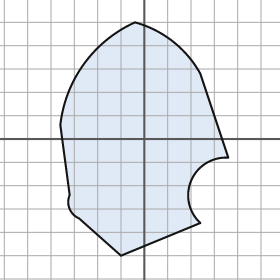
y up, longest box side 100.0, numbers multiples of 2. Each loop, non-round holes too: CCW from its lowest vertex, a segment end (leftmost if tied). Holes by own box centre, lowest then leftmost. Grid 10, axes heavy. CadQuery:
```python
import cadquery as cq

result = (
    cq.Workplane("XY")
    .moveTo(-10.0, -50.0)
    .lineTo(24.0, -36.0)
    .threePointArc((20.0, -18.0), (36.0, -8.0))
    .lineTo(24.0, 28.0)
    .threePointArc((12.0, 42.0), (-4.0, 50.0))
    .threePointArc((-26.0, 32.0), (-36.0, 6.0))
    .lineTo(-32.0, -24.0)
    .threePointArc((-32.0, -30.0), (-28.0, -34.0))
    .close()
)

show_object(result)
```